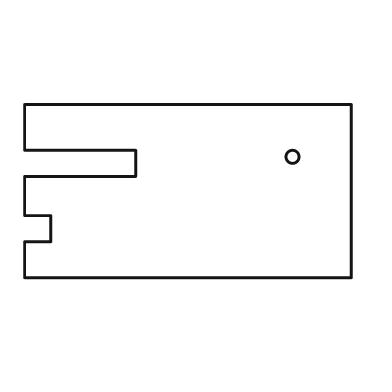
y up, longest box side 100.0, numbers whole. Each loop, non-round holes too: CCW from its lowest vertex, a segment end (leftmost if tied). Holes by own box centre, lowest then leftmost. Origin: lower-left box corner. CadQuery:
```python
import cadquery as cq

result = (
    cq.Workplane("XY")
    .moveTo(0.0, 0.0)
    .lineTo(100.0, 0.0)
    .lineTo(100.0, 53.0)
    .lineTo(0.0, 53.0)
    .lineTo(0.0, 39.0)
    .lineTo(34.0, 39.0)
    .lineTo(34.0, 31.0)
    .lineTo(0.0, 31.0)
    .lineTo(0.0, 19.0)
    .lineTo(8.0, 19.0)
    .lineTo(8.0, 11.0)
    .lineTo(0.0, 11.0)
    .close()
    .moveTo(82.0, 37.0)
    .circle(2.0)
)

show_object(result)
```